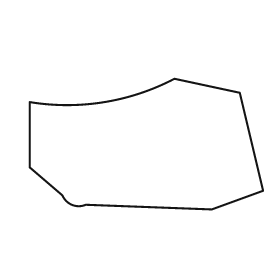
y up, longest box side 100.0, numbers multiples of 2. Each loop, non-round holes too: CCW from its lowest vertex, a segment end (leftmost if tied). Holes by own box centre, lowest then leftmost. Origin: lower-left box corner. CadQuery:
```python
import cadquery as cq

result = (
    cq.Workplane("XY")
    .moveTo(78.0, 0.0)
    .lineTo(100.0, 8.0)
    .lineTo(90.0, 50.0)
    .lineTo(62.0, 56.0)
    .threePointArc((32.0, 46.0), (0.0, 46.0))
    .lineTo(0.0, 18.0)
    .lineTo(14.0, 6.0)
    .threePointArc((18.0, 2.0), (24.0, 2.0))
    .close()
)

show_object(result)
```